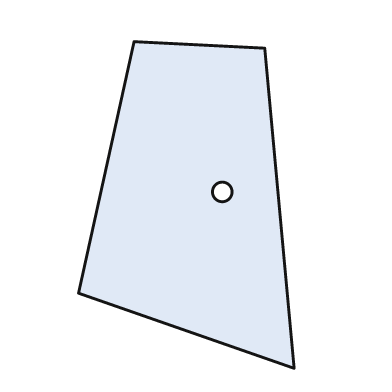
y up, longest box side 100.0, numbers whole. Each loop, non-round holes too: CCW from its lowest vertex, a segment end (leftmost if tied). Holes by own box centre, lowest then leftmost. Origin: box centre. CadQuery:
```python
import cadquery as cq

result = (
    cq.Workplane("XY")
    .moveTo(33.0, -50.0)
    .lineTo(24.0, 48.0)
    .lineTo(-16.0, 50.0)
    .lineTo(-33.0, -27.0)
    .close()
    .moveTo(11.0, 4.0)
    .circle(3.0)
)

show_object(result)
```